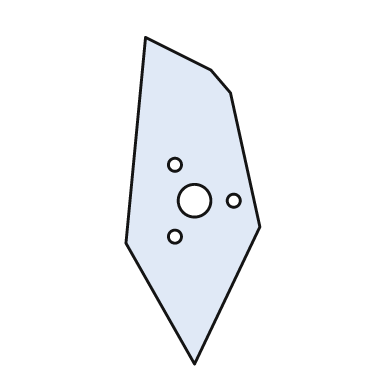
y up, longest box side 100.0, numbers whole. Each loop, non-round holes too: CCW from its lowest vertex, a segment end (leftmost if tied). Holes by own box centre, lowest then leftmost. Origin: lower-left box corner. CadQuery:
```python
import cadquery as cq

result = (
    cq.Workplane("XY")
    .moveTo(21.0, 0.0)
    .lineTo(41.0, 42.0)
    .lineTo(32.0, 83.0)
    .lineTo(26.0, 90.0)
    .lineTo(6.0, 100.0)
    .lineTo(0.0, 37.0)
    .close()
    .moveTo(15.0, 39.0)
    .circle(2.0)
    .moveTo(21.0, 50.0)
    .circle(5.0)
    .moveTo(33.0, 50.0)
    .circle(2.0)
    .moveTo(15.0, 61.0)
    .circle(2.0)
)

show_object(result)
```